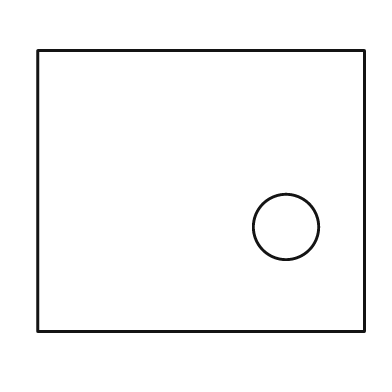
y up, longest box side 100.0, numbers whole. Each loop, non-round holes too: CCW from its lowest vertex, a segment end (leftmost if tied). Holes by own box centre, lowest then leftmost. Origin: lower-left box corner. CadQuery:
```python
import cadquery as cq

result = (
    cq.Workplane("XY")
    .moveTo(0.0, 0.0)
    .lineTo(100.0, 0.0)
    .lineTo(100.0, 86.0)
    .lineTo(0.0, 86.0)
    .close()
    .moveTo(76.0, 32.0)
    .circle(10.0)
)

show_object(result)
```